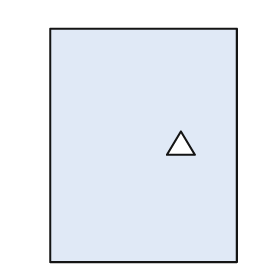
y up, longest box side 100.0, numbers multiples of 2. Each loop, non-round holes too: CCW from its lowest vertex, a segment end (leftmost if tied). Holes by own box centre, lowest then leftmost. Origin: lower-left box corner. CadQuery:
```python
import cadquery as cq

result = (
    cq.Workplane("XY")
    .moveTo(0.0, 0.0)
    .lineTo(80.0, 0.0)
    .lineTo(80.0, 100.0)
    .lineTo(0.0, 100.0)
    .close()
    .moveTo(50.0, 46.0)
    .lineTo(62.0, 46.0)
    .lineTo(56.0, 56.0)
    .close()
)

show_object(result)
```